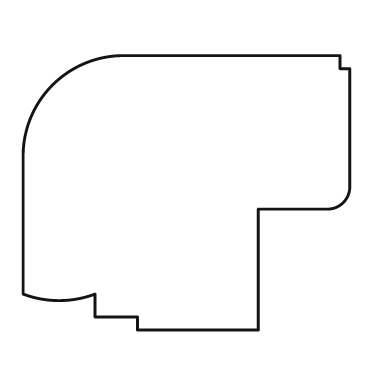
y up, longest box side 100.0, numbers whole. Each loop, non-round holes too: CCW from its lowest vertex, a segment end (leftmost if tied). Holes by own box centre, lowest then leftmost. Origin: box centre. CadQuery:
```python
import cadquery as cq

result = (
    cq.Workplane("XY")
    .moveTo(-15.0, -42.0)
    .lineTo(22.0, -42.0)
    .lineTo(22.0, -5.0)
    .lineTo(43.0, -5.0)
    .threePointArc((48.0, -3.0), (50.0, 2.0))
    .lineTo(50.0, 38.0)
    .lineTo(47.0, 38.0)
    .lineTo(47.0, 42.0)
    .lineTo(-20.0, 42.0)
    .threePointArc((-41.0, 33.0), (-50.0, 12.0))
    .lineTo(-50.0, -31.0)
    .threePointArc((-39.0, -33.0), (-28.0, -31.0))
    .lineTo(-28.0, -38.0)
    .lineTo(-15.0, -38.0)
    .close()
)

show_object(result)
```